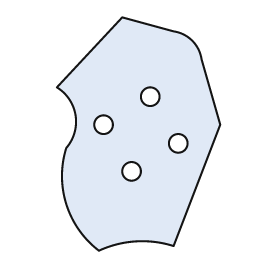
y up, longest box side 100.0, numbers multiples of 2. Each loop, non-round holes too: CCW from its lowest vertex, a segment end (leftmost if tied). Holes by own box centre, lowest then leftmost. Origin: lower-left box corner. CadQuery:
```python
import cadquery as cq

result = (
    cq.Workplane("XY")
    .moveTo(18.0, 0.0)
    .threePointArc((34.0, 4.0), (50.0, 2.0))
    .lineTo(70.0, 54.0)
    .lineTo(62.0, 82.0)
    .threePointArc((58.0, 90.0), (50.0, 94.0))
    .lineTo(28.0, 100.0)
    .lineTo(0.0, 70.0)
    .threePointArc((8.0, 58.0), (4.0, 44.0))
    .threePointArc((4.0, 20.0), (18.0, 0.0))
    .close()
    .moveTo(32.0, 34.0)
    .circle(4.0)
    .moveTo(52.0, 46.0)
    .circle(4.0)
    .moveTo(20.0, 54.0)
    .circle(4.0)
    .moveTo(40.0, 66.0)
    .circle(4.0)
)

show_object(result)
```